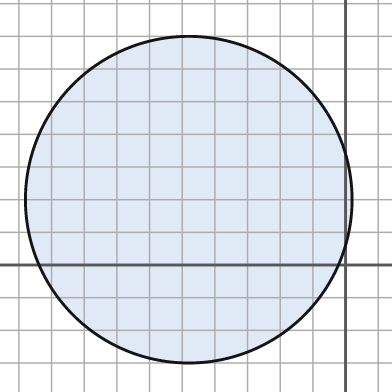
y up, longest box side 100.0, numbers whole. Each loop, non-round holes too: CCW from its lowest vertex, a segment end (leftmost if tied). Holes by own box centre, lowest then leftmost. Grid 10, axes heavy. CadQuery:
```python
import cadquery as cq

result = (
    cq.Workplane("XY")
    .moveTo(-48.0, 20.0)
    .circle(50.0)
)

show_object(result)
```